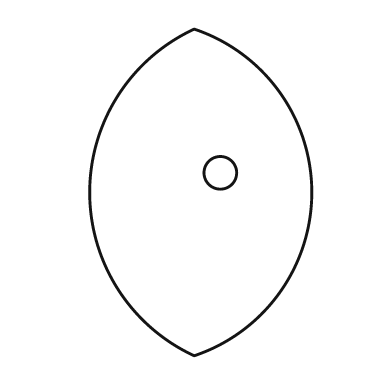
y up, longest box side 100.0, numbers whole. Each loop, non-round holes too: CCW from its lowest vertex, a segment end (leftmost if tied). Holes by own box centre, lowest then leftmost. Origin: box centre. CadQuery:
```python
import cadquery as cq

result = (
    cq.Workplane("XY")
    .moveTo(-2.0, -50.0)
    .threePointArc((34.0, 0.0), (-2.0, 50.0))
    .threePointArc((-34.0, 0.0), (-2.0, -50.0))
    .close()
    .moveTo(6.0, 6.0)
    .circle(5.0)
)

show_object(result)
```